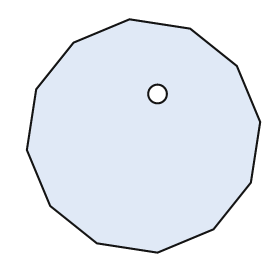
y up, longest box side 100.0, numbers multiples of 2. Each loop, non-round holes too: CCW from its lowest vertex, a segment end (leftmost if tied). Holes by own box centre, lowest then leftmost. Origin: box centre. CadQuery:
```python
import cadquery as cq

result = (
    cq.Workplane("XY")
    .moveTo(6.0, -50.0)
    .lineTo(30.0, -40.0)
    .lineTo(46.0, -20.0)
    .lineTo(50.0, 6.0)
    .lineTo(40.0, 30.0)
    .lineTo(20.0, 46.0)
    .lineTo(-6.0, 50.0)
    .lineTo(-30.0, 40.0)
    .lineTo(-46.0, 20.0)
    .lineTo(-50.0, -6.0)
    .lineTo(-40.0, -30.0)
    .lineTo(-20.0, -46.0)
    .close()
    .moveTo(6.0, 18.0)
    .circle(4.0)
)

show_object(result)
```